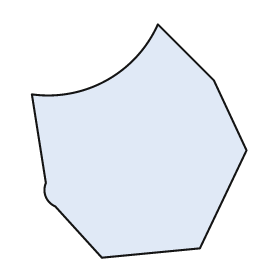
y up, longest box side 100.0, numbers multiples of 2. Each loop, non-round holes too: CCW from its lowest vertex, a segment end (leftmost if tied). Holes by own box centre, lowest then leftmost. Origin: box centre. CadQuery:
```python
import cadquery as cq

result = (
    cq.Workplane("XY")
    .moveTo(-16.0, -50.0)
    .lineTo(26.0, -46.0)
    .lineTo(46.0, -4.0)
    .lineTo(32.0, 26.0)
    .lineTo(8.0, 50.0)
    .threePointArc((-14.0, 26.0), (-46.0, 20.0))
    .lineTo(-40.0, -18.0)
    .threePointArc((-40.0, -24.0), (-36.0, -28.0))
    .close()
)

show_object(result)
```